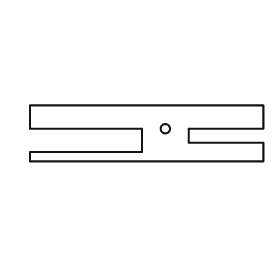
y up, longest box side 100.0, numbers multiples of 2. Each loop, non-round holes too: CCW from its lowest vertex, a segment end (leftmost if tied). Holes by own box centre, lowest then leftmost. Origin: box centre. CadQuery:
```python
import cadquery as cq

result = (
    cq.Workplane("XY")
    .moveTo(-50.0, -12.0)
    .lineTo(50.0, -12.0)
    .lineTo(50.0, -4.0)
    .lineTo(18.0, -4.0)
    .lineTo(18.0, 2.0)
    .lineTo(50.0, 2.0)
    .lineTo(50.0, 12.0)
    .lineTo(-50.0, 12.0)
    .lineTo(-50.0, 2.0)
    .lineTo(-2.0, 2.0)
    .lineTo(-2.0, -8.0)
    .lineTo(-50.0, -8.0)
    .close()
    .moveTo(8.0, 2.0)
    .circle(2.0)
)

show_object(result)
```